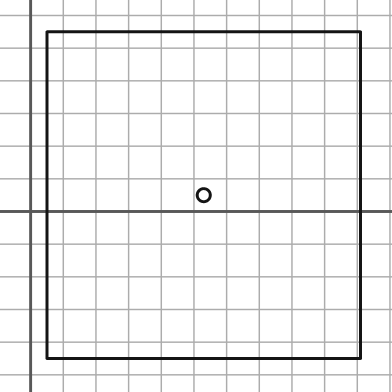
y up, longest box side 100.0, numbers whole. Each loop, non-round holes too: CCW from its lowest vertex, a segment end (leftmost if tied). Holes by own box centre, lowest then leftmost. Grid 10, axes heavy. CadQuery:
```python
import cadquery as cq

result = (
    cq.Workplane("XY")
    .moveTo(5.0, -45.0)
    .lineTo(101.0, -45.0)
    .lineTo(101.0, 55.0)
    .lineTo(5.0, 55.0)
    .close()
    .moveTo(53.0, 5.0)
    .circle(2.0)
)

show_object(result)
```